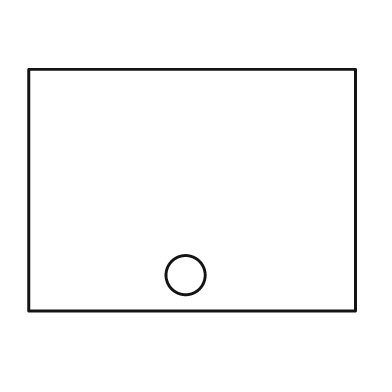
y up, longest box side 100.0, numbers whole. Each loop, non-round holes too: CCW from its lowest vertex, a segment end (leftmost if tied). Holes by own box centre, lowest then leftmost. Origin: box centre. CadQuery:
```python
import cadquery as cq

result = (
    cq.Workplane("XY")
    .moveTo(-50.0, -37.0)
    .lineTo(50.0, -37.0)
    .lineTo(50.0, 37.0)
    .lineTo(-50.0, 37.0)
    .close()
    .moveTo(-2.0, -26.0)
    .circle(6.0)
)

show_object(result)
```